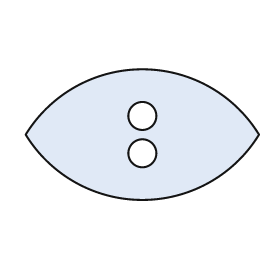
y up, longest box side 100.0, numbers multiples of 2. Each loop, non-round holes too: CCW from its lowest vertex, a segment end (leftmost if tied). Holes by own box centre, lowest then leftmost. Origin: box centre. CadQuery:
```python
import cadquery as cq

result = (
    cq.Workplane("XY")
    .moveTo(-50.0, 0.0)
    .threePointArc((0.0, -28.0), (50.0, 0.0))
    .threePointArc((0.0, 28.0), (-50.0, 0.0))
    .close()
    .moveTo(0.0, -8.0)
    .circle(6.0)
    .moveTo(0.0, 8.0)
    .circle(6.0)
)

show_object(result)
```